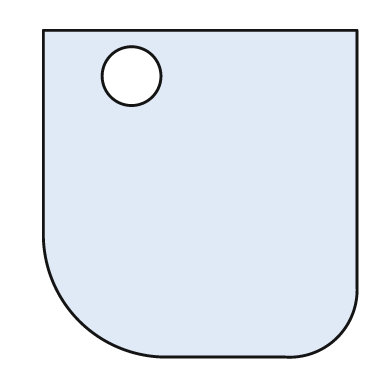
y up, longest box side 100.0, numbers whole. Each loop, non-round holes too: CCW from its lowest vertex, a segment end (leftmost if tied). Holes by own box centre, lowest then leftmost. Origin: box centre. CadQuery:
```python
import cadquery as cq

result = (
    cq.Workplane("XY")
    .moveTo(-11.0, -50.0)
    .lineTo(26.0, -50.0)
    .threePointArc((42.0, -44.0), (48.0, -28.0))
    .lineTo(48.0, 50.0)
    .lineTo(-48.0, 50.0)
    .lineTo(-48.0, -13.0)
    .threePointArc((-37.0, -39.0), (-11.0, -50.0))
    .close()
    .moveTo(-21.0, 36.0)
    .circle(9.0)
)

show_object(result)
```